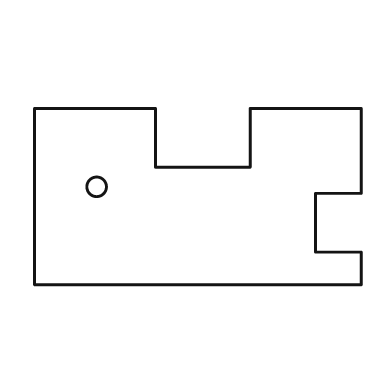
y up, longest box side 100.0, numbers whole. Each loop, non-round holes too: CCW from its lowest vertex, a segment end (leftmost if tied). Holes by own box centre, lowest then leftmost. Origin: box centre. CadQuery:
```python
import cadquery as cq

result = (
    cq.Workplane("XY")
    .moveTo(-50.0, -27.0)
    .lineTo(50.0, -27.0)
    .lineTo(50.0, -17.0)
    .lineTo(36.0, -17.0)
    .lineTo(36.0, 1.0)
    .lineTo(50.0, 1.0)
    .lineTo(50.0, 27.0)
    .lineTo(16.0, 27.0)
    .lineTo(16.0, 9.0)
    .lineTo(-13.0, 9.0)
    .lineTo(-13.0, 27.0)
    .lineTo(-50.0, 27.0)
    .close()
    .moveTo(-31.0, 3.0)
    .circle(3.0)
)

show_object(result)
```